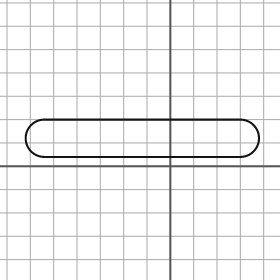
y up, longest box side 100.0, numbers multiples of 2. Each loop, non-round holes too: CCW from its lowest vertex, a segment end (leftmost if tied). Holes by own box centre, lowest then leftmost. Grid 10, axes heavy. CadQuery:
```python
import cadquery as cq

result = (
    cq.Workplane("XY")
    .moveTo(-54.0, 4.0)
    .lineTo(30.0, 4.0)
    .threePointArc((38.0, 12.0), (30.0, 20.0))
    .lineTo(-54.0, 20.0)
    .threePointArc((-62.0, 12.0), (-54.0, 4.0))
    .close()
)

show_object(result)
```